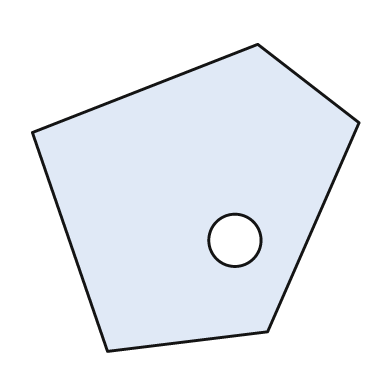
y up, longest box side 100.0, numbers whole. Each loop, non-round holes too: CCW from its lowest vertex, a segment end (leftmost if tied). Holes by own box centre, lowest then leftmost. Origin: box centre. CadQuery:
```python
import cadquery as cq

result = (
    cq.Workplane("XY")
    .moveTo(-27.0, -47.0)
    .lineTo(22.0, -41.0)
    .lineTo(50.0, 23.0)
    .lineTo(19.0, 47.0)
    .lineTo(-50.0, 20.0)
    .close()
    .moveTo(12.0, -13.0)
    .circle(8.0)
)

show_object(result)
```